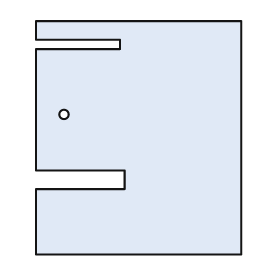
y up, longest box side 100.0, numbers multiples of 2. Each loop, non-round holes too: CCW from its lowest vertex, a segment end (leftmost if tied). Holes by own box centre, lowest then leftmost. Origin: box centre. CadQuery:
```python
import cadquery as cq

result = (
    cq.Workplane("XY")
    .moveTo(-44.0, -50.0)
    .lineTo(44.0, -50.0)
    .lineTo(44.0, 50.0)
    .lineTo(-44.0, 50.0)
    .lineTo(-44.0, 42.0)
    .lineTo(-8.0, 42.0)
    .lineTo(-8.0, 38.0)
    .lineTo(-44.0, 38.0)
    .lineTo(-44.0, -14.0)
    .lineTo(-6.0, -14.0)
    .lineTo(-6.0, -22.0)
    .lineTo(-44.0, -22.0)
    .close()
    .moveTo(-32.0, 10.0)
    .circle(2.0)
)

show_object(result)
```